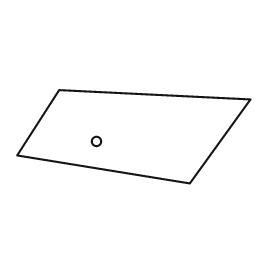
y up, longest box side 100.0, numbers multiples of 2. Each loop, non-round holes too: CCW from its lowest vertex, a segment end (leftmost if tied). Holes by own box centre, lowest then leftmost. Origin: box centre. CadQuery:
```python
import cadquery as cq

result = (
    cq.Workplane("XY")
    .moveTo(24.0, -20.0)
    .lineTo(50.0, 16.0)
    .lineTo(-32.0, 20.0)
    .lineTo(-50.0, -8.0)
    .close()
    .moveTo(-16.0, -2.0)
    .circle(2.0)
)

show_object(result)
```